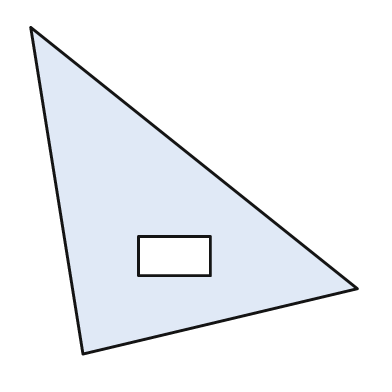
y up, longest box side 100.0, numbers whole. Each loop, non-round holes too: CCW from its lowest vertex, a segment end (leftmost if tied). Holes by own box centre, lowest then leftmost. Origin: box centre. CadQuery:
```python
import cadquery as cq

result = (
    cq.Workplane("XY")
    .moveTo(-34.0, -50.0)
    .lineTo(50.0, -30.0)
    .lineTo(-50.0, 50.0)
    .close()
    .moveTo(-17.0, -26.0)
    .lineTo(5.0, -26.0)
    .lineTo(5.0, -14.0)
    .lineTo(-17.0, -14.0)
    .close()
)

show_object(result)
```